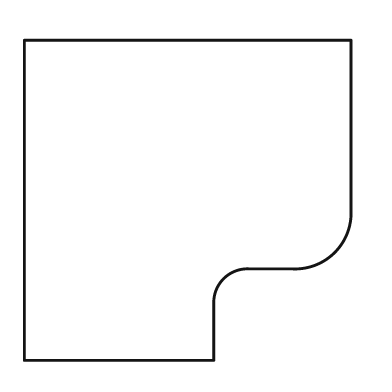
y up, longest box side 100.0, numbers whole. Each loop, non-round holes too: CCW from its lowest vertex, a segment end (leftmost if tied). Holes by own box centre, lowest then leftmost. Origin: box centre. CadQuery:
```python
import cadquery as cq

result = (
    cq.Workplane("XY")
    .moveTo(-50.0, -49.0)
    .lineTo(8.0, -49.0)
    .lineTo(8.0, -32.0)
    .threePointArc((11.0, -24.0), (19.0, -21.0))
    .lineTo(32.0, -21.0)
    .threePointArc((45.0, -16.0), (50.0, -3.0))
    .lineTo(50.0, 49.0)
    .lineTo(-50.0, 49.0)
    .close()
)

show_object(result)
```